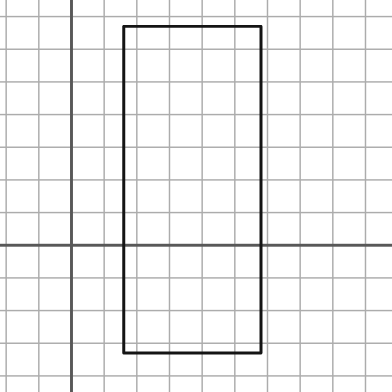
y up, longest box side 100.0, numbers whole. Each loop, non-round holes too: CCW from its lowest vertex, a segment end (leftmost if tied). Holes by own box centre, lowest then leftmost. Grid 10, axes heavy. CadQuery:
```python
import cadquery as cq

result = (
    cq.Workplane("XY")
    .moveTo(16.0, -33.0)
    .lineTo(58.0, -33.0)
    .lineTo(58.0, 67.0)
    .lineTo(16.0, 67.0)
    .close()
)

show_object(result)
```